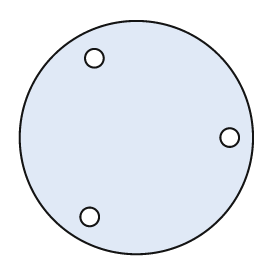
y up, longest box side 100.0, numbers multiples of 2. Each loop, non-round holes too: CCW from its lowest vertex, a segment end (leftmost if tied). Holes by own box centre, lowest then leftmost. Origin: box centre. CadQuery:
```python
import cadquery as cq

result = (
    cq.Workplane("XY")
    .moveTo(0.0, 0.0)
    .circle(50.0)
    .moveTo(-20.0, -34.0)
    .circle(4.0)
    .moveTo(40.0, 0.0)
    .circle(4.0)
    .moveTo(-18.0, 34.0)
    .circle(4.0)
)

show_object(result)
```